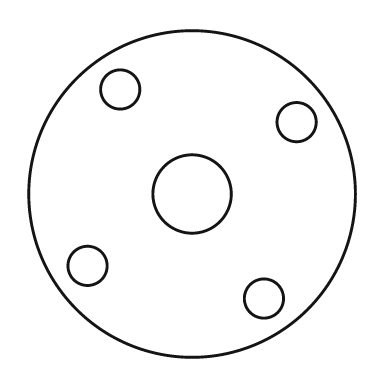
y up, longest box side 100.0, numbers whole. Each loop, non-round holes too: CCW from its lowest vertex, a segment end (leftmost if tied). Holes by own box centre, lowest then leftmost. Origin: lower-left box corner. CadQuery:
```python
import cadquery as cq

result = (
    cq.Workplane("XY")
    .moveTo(50.0, 50.0)
    .circle(50.0)
    .moveTo(72.0, 18.0)
    .circle(6.0)
    .moveTo(18.0, 28.0)
    .circle(6.0)
    .moveTo(50.0, 50.0)
    .circle(12.0)
    .moveTo(82.0, 72.0)
    .circle(6.0)
    .moveTo(28.0, 82.0)
    .circle(6.0)
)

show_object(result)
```